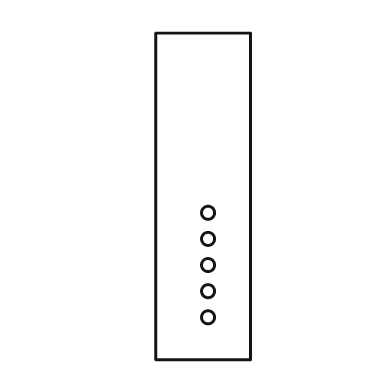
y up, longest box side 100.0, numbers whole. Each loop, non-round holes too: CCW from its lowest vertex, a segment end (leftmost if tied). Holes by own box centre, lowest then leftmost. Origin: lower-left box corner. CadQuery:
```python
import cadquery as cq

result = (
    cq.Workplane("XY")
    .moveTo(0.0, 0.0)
    .lineTo(29.0, 0.0)
    .lineTo(29.0, 100.0)
    .lineTo(0.0, 100.0)
    .close()
    .moveTo(16.0, 13.0)
    .circle(2.0)
    .moveTo(16.0, 21.0)
    .circle(2.0)
    .moveTo(16.0, 29.0)
    .circle(2.0)
    .moveTo(16.0, 37.0)
    .circle(2.0)
    .moveTo(16.0, 45.0)
    .circle(2.0)
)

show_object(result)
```